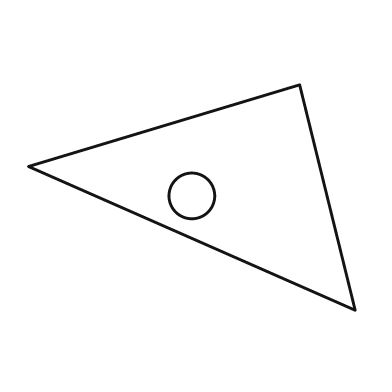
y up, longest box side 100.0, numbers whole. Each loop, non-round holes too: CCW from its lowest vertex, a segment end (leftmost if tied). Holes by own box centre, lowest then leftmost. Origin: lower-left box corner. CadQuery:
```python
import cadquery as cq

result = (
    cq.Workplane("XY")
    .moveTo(100.0, 0.0)
    .lineTo(83.0, 69.0)
    .lineTo(0.0, 44.0)
    .close()
    .moveTo(50.0, 35.0)
    .circle(7.0)
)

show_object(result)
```